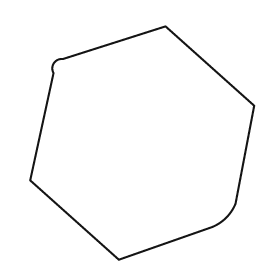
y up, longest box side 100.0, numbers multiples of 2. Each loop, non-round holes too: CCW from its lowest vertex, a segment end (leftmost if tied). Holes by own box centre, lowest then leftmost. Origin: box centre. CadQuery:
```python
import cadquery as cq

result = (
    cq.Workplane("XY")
    .moveTo(-10.0, -50.0)
    .lineTo(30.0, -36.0)
    .threePointArc((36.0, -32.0), (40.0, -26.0))
    .lineTo(48.0, 16.0)
    .lineTo(10.0, 50.0)
    .lineTo(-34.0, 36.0)
    .threePointArc((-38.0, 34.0), (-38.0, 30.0))
    .lineTo(-48.0, -16.0)
    .close()
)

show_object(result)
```